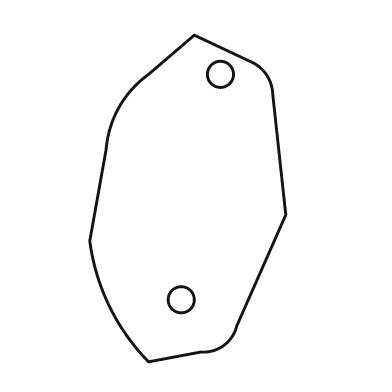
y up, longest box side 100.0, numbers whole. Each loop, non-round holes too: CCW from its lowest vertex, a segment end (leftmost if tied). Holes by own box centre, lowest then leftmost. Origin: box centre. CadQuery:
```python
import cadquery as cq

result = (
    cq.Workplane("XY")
    .moveTo(-12.0, -50.0)
    .lineTo(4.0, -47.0)
    .threePointArc((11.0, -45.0), (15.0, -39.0))
    .lineTo(30.0, -5.0)
    .lineTo(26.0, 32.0)
    .threePointArc((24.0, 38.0), (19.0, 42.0))
    .lineTo(2.0, 50.0)
    .lineTo(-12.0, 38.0)
    .threePointArc((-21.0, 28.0), (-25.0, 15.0))
    .lineTo(-30.0, -13.0)
    .threePointArc((-24.0, -33.0), (-12.0, -50.0))
    .close()
    .moveTo(-2.0, -31.0)
    .circle(4.0)
    .moveTo(10.0, 38.0)
    .circle(4.0)
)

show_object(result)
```